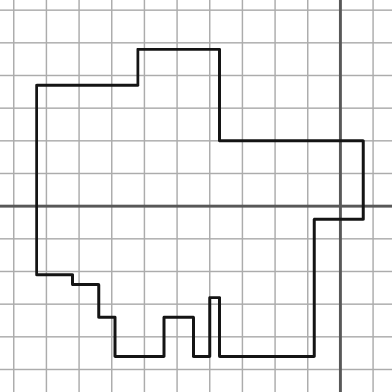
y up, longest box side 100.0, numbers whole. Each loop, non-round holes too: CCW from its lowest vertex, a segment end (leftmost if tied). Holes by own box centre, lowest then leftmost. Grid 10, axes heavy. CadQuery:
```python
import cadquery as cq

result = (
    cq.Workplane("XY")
    .moveTo(-69.0, -46.0)
    .lineTo(-54.0, -46.0)
    .lineTo(-54.0, -34.0)
    .lineTo(-45.0, -34.0)
    .lineTo(-45.0, -46.0)
    .lineTo(-40.0, -46.0)
    .lineTo(-40.0, -28.0)
    .lineTo(-37.0, -28.0)
    .lineTo(-37.0, -46.0)
    .lineTo(-8.0, -46.0)
    .lineTo(-8.0, -4.0)
    .lineTo(7.0, -4.0)
    .lineTo(7.0, 20.0)
    .lineTo(-37.0, 20.0)
    .lineTo(-37.0, 48.0)
    .lineTo(-62.0, 48.0)
    .lineTo(-62.0, 37.0)
    .lineTo(-93.0, 37.0)
    .lineTo(-93.0, -21.0)
    .lineTo(-82.0, -21.0)
    .lineTo(-82.0, -24.0)
    .lineTo(-74.0, -24.0)
    .lineTo(-74.0, -34.0)
    .lineTo(-69.0, -34.0)
    .close()
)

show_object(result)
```